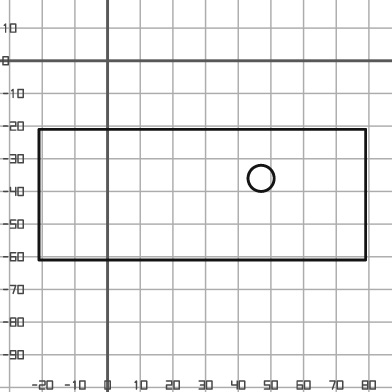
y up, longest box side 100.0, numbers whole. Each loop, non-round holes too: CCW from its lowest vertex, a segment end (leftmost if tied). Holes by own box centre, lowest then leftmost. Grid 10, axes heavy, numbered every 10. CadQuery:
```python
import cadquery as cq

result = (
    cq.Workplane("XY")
    .moveTo(-21.0, -61.0)
    .lineTo(79.0, -61.0)
    .lineTo(79.0, -21.0)
    .lineTo(-21.0, -21.0)
    .close()
    .moveTo(47.0, -36.0)
    .circle(4.0)
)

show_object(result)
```